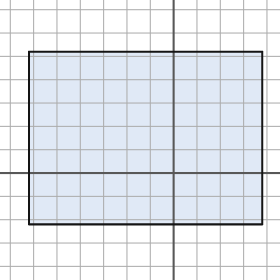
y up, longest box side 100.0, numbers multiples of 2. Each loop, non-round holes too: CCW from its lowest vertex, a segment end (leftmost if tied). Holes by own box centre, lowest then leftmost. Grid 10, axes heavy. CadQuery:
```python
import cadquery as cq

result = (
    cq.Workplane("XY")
    .moveTo(-62.0, -22.0)
    .lineTo(38.0, -22.0)
    .lineTo(38.0, 52.0)
    .lineTo(-62.0, 52.0)
    .close()
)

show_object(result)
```